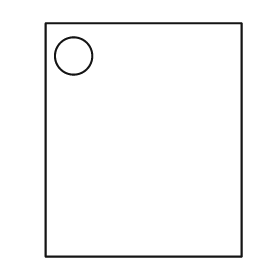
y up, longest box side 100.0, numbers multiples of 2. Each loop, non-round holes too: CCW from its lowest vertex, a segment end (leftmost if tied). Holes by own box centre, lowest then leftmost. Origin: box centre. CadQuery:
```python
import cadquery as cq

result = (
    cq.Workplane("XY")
    .moveTo(-42.0, -50.0)
    .lineTo(42.0, -50.0)
    .lineTo(42.0, 50.0)
    .lineTo(-42.0, 50.0)
    .close()
    .moveTo(-30.0, 36.0)
    .circle(8.0)
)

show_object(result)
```